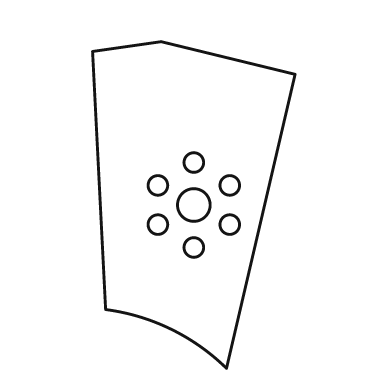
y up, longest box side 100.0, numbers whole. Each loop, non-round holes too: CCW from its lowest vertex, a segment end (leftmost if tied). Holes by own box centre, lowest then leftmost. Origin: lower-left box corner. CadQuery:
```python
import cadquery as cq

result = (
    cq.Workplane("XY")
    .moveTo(41.0, 0.0)
    .lineTo(62.0, 90.0)
    .lineTo(21.0, 100.0)
    .lineTo(0.0, 97.0)
    .lineTo(4.0, 18.0)
    .threePointArc((24.0, 12.0), (41.0, 0.0))
    .close()
    .moveTo(31.0, 37.0)
    .circle(3.0)
    .moveTo(20.0, 44.0)
    .circle(3.0)
    .moveTo(42.0, 44.0)
    .circle(3.0)
    .moveTo(31.0, 50.0)
    .circle(5.0)
    .moveTo(20.0, 56.0)
    .circle(3.0)
    .moveTo(42.0, 56.0)
    .circle(3.0)
    .moveTo(31.0, 63.0)
    .circle(3.0)
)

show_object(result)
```